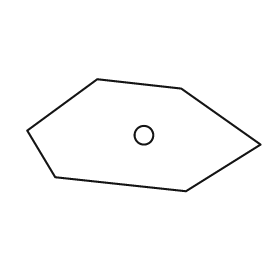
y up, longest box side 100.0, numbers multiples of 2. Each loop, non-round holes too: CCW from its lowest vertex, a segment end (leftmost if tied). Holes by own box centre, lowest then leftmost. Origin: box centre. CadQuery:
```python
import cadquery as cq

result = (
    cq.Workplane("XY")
    .moveTo(18.0, -24.0)
    .lineTo(50.0, -4.0)
    .lineTo(16.0, 20.0)
    .lineTo(-20.0, 24.0)
    .lineTo(-50.0, 2.0)
    .lineTo(-38.0, -18.0)
    .close()
    .moveTo(0.0, 0.0)
    .circle(4.0)
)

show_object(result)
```